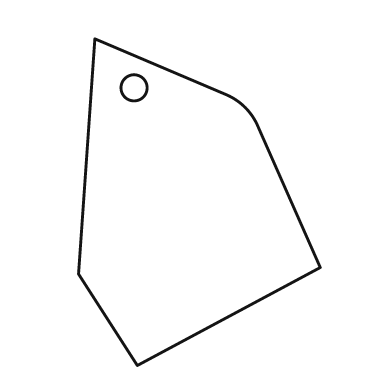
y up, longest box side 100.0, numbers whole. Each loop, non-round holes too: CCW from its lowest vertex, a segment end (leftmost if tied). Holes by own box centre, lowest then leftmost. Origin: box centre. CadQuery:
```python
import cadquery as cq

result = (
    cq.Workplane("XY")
    .moveTo(-19.0, -50.0)
    .lineTo(37.0, -20.0)
    .lineTo(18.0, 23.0)
    .threePointArc((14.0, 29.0), (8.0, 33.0))
    .lineTo(-32.0, 50.0)
    .lineTo(-37.0, -22.0)
    .close()
    .moveTo(-20.0, 35.0)
    .circle(4.0)
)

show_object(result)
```